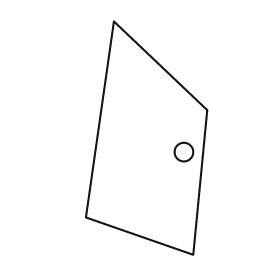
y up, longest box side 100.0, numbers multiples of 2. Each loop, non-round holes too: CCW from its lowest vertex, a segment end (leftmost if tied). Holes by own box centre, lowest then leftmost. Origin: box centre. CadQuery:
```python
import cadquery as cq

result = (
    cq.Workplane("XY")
    .moveTo(20.0, -50.0)
    .lineTo(26.0, 12.0)
    .lineTo(-14.0, 50.0)
    .lineTo(-26.0, -34.0)
    .close()
    .moveTo(16.0, -6.0)
    .circle(4.0)
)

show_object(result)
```